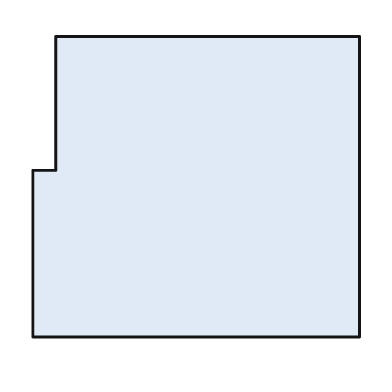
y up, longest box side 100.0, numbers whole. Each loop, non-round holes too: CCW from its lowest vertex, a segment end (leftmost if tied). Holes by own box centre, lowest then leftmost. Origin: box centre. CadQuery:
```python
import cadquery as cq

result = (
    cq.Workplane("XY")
    .moveTo(-50.0, -46.0)
    .lineTo(50.0, -46.0)
    .lineTo(50.0, 46.0)
    .lineTo(-43.0, 46.0)
    .lineTo(-43.0, 5.0)
    .lineTo(-50.0, 5.0)
    .close()
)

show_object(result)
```